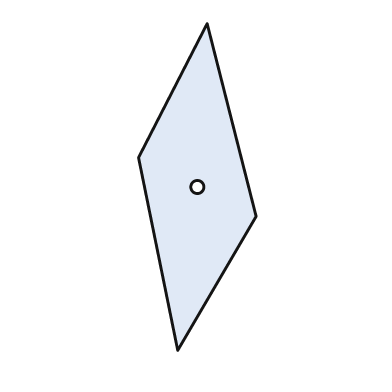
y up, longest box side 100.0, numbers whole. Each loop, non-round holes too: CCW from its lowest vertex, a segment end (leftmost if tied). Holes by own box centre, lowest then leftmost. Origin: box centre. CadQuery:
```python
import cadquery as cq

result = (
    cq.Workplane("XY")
    .moveTo(-6.0, -50.0)
    .lineTo(18.0, -9.0)
    .lineTo(3.0, 50.0)
    .lineTo(-18.0, 9.0)
    .close()
    .moveTo(0.0, 0.0)
    .circle(2.0)
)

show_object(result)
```